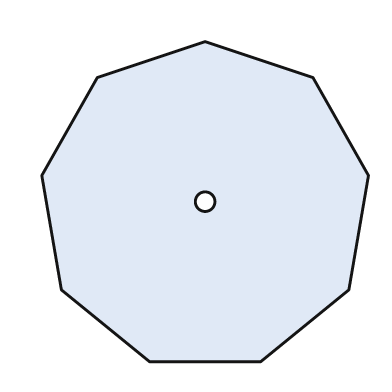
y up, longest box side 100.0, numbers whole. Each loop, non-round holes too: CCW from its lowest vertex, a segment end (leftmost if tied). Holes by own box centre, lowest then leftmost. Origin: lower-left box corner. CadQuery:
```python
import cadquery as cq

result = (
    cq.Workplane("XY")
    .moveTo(33.0, 0.0)
    .lineTo(67.0, 0.0)
    .lineTo(94.0, 22.0)
    .lineTo(100.0, 57.0)
    .lineTo(83.0, 87.0)
    .lineTo(50.0, 98.0)
    .lineTo(17.0, 87.0)
    .lineTo(0.0, 57.0)
    .lineTo(6.0, 22.0)
    .close()
    .moveTo(50.0, 49.0)
    .circle(3.0)
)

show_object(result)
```